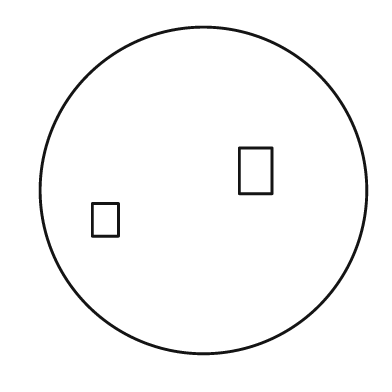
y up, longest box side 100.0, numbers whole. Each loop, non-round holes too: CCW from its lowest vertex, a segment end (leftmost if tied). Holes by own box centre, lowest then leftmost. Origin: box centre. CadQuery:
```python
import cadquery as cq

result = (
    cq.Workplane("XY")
    .moveTo(0.0, 0.0)
    .circle(50.0)
    .moveTo(-34.0, -14.0)
    .lineTo(-26.0, -14.0)
    .lineTo(-26.0, -4.0)
    .lineTo(-34.0, -4.0)
    .close()
    .moveTo(11.0, -1.0)
    .lineTo(21.0, -1.0)
    .lineTo(21.0, 13.0)
    .lineTo(11.0, 13.0)
    .close()
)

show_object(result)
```